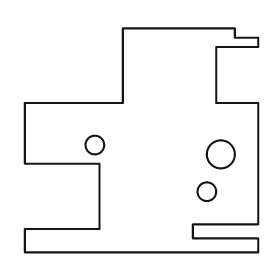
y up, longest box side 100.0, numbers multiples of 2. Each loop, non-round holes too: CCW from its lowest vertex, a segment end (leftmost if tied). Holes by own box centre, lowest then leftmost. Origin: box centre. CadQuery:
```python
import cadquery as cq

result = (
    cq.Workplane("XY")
    .moveTo(-50.0, -48.0)
    .lineTo(50.0, -48.0)
    .lineTo(50.0, -42.0)
    .lineTo(22.0, -42.0)
    .lineTo(22.0, -36.0)
    .lineTo(50.0, -36.0)
    .lineTo(50.0, 16.0)
    .lineTo(32.0, 16.0)
    .lineTo(32.0, 40.0)
    .lineTo(50.0, 40.0)
    .lineTo(50.0, 44.0)
    .lineTo(40.0, 44.0)
    .lineTo(40.0, 48.0)
    .lineTo(-8.0, 48.0)
    .lineTo(-8.0, 16.0)
    .lineTo(-50.0, 16.0)
    .lineTo(-50.0, -10.0)
    .lineTo(-18.0, -10.0)
    .lineTo(-18.0, -38.0)
    .lineTo(-50.0, -38.0)
    .close()
    .moveTo(28.0, -22.0)
    .circle(4.0)
    .moveTo(34.0, -6.0)
    .circle(6.0)
    .moveTo(-20.0, -2.0)
    .circle(4.0)
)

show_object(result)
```